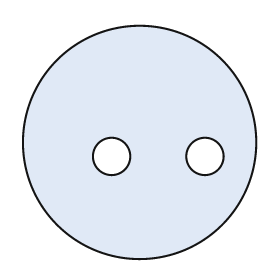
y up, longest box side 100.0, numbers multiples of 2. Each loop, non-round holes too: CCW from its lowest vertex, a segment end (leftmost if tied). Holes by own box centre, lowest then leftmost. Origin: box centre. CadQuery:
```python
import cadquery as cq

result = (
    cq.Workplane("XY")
    .moveTo(0.0, 0.0)
    .circle(50.0)
    .moveTo(-12.0, -6.0)
    .circle(8.0)
    .moveTo(28.0, -6.0)
    .circle(8.0)
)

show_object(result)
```